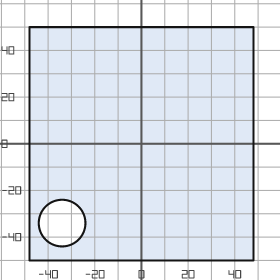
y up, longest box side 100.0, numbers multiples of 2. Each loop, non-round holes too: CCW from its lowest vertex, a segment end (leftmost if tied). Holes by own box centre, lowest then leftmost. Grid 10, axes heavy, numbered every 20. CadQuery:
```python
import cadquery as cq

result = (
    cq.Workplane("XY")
    .moveTo(-48.0, -50.0)
    .lineTo(48.0, -50.0)
    .lineTo(48.0, 50.0)
    .lineTo(-48.0, 50.0)
    .close()
    .moveTo(-34.0, -34.0)
    .circle(10.0)
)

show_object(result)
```